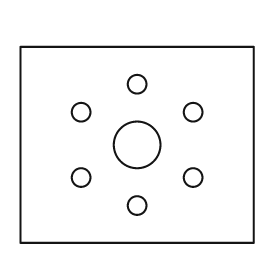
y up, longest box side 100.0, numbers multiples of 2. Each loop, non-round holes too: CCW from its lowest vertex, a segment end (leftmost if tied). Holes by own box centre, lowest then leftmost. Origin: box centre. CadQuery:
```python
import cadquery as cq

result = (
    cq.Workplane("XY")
    .moveTo(-50.0, -42.0)
    .lineTo(50.0, -42.0)
    .lineTo(50.0, 42.0)
    .lineTo(-50.0, 42.0)
    .close()
    .moveTo(0.0, -26.0)
    .circle(4.0)
    .moveTo(-24.0, -14.0)
    .circle(4.0)
    .moveTo(24.0, -14.0)
    .circle(4.0)
    .moveTo(0.0, 0.0)
    .circle(10.0)
    .moveTo(-24.0, 14.0)
    .circle(4.0)
    .moveTo(24.0, 14.0)
    .circle(4.0)
    .moveTo(0.0, 26.0)
    .circle(4.0)
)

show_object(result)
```